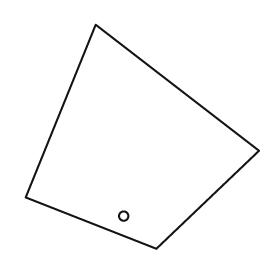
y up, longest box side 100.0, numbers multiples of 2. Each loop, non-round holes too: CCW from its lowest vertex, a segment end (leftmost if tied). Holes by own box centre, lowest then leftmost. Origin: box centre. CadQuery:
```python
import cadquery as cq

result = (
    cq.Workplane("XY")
    .moveTo(6.0, -48.0)
    .lineTo(50.0, -6.0)
    .lineTo(-20.0, 48.0)
    .lineTo(-50.0, -26.0)
    .close()
    .moveTo(-8.0, -34.0)
    .circle(2.0)
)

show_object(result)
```